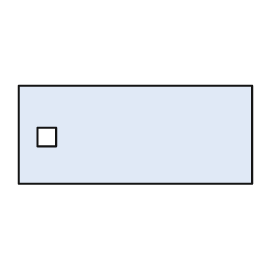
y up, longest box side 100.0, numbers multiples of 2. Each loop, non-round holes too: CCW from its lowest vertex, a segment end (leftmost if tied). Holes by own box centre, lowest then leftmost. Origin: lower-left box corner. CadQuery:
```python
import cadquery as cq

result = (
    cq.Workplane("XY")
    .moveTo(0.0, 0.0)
    .lineTo(100.0, 0.0)
    .lineTo(100.0, 42.0)
    .lineTo(0.0, 42.0)
    .close()
    .moveTo(8.0, 16.0)
    .lineTo(16.0, 16.0)
    .lineTo(16.0, 24.0)
    .lineTo(8.0, 24.0)
    .close()
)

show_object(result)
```